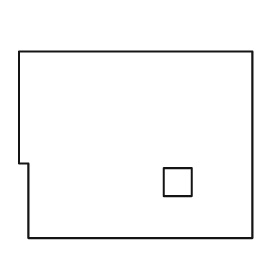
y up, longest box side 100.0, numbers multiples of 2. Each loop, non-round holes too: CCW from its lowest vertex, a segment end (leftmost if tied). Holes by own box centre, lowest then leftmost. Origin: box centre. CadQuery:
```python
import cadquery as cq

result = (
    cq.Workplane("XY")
    .moveTo(-46.0, -40.0)
    .lineTo(50.0, -40.0)
    .lineTo(50.0, 40.0)
    .lineTo(-50.0, 40.0)
    .lineTo(-50.0, -8.0)
    .lineTo(-46.0, -8.0)
    .close()
    .moveTo(12.0, -22.0)
    .lineTo(24.0, -22.0)
    .lineTo(24.0, -10.0)
    .lineTo(12.0, -10.0)
    .close()
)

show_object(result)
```